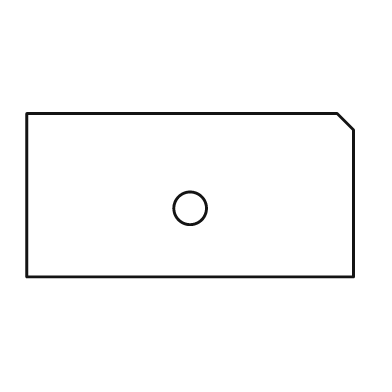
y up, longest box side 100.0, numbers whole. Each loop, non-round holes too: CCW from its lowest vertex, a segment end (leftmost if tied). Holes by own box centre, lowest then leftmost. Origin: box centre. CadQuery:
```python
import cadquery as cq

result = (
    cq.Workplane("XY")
    .moveTo(-50.0, -25.0)
    .lineTo(50.0, -25.0)
    .lineTo(50.0, 20.0)
    .lineTo(45.0, 25.0)
    .lineTo(-50.0, 25.0)
    .close()
    .moveTo(0.0, -4.0)
    .circle(5.0)
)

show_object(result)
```